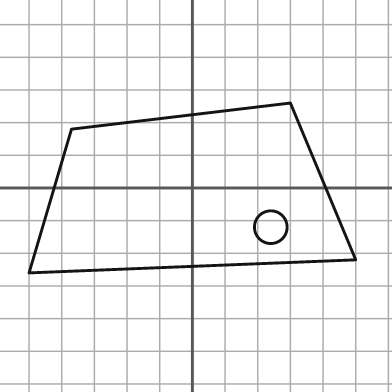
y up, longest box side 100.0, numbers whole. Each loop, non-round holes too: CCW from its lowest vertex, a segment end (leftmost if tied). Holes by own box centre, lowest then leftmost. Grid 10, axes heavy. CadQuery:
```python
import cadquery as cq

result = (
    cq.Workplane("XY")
    .moveTo(-50.0, -26.0)
    .lineTo(50.0, -22.0)
    .lineTo(30.0, 26.0)
    .lineTo(-37.0, 18.0)
    .close()
    .moveTo(24.0, -12.0)
    .circle(5.0)
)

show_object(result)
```